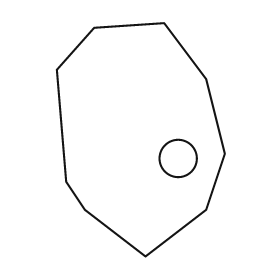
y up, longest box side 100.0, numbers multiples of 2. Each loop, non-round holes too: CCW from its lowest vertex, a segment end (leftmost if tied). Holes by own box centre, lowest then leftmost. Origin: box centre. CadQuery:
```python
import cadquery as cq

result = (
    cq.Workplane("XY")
    .moveTo(2.0, -50.0)
    .lineTo(28.0, -30.0)
    .lineTo(36.0, -6.0)
    .lineTo(28.0, 26.0)
    .lineTo(10.0, 50.0)
    .lineTo(-20.0, 48.0)
    .lineTo(-36.0, 30.0)
    .lineTo(-32.0, -18.0)
    .lineTo(-24.0, -30.0)
    .close()
    .moveTo(16.0, -8.0)
    .circle(8.0)
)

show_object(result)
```